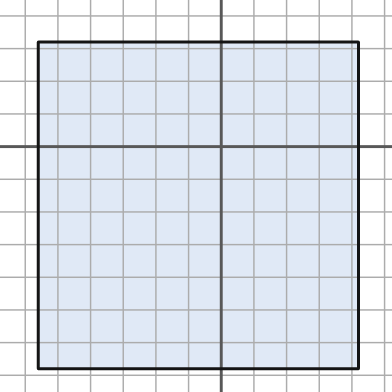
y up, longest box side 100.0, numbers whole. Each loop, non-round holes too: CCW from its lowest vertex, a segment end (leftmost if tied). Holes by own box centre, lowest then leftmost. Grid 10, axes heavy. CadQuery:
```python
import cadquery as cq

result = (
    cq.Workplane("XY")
    .moveTo(-56.0, -68.0)
    .lineTo(42.0, -68.0)
    .lineTo(42.0, 32.0)
    .lineTo(-56.0, 32.0)
    .close()
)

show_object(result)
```